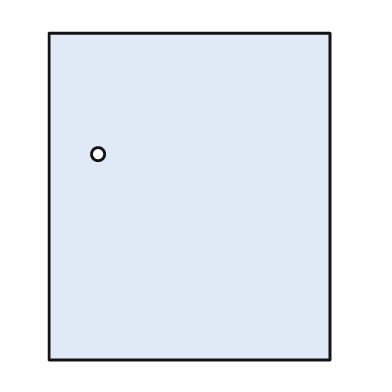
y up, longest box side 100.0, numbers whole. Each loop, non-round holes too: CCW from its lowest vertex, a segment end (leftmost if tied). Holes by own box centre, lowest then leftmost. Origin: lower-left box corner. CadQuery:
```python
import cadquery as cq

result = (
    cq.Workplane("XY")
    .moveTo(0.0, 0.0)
    .lineTo(86.0, 0.0)
    .lineTo(86.0, 100.0)
    .lineTo(0.0, 100.0)
    .close()
    .moveTo(15.0, 63.0)
    .circle(2.0)
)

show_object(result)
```